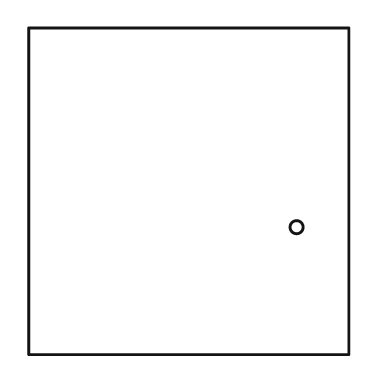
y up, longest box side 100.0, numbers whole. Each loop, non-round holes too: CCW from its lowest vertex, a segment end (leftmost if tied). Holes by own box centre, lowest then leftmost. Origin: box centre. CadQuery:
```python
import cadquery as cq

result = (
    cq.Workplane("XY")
    .moveTo(-49.0, -50.0)
    .lineTo(49.0, -50.0)
    .lineTo(49.0, 50.0)
    .lineTo(-49.0, 50.0)
    .close()
    .moveTo(33.0, -11.0)
    .circle(2.0)
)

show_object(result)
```